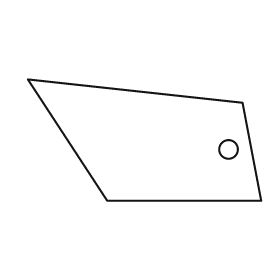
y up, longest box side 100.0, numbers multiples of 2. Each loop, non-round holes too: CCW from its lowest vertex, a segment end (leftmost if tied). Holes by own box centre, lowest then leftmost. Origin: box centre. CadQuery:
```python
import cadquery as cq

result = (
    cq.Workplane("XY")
    .moveTo(-16.0, -26.0)
    .lineTo(50.0, -26.0)
    .lineTo(42.0, 16.0)
    .lineTo(-50.0, 26.0)
    .close()
    .moveTo(36.0, -4.0)
    .circle(4.0)
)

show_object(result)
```